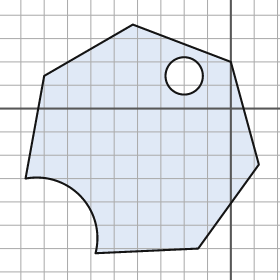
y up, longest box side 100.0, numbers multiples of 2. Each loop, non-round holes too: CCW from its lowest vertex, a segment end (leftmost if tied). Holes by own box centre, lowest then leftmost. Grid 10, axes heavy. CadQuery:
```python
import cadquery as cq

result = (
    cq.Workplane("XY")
    .moveTo(-58.0, -62.0)
    .lineTo(-14.0, -60.0)
    .lineTo(12.0, -24.0)
    .lineTo(0.0, 20.0)
    .lineTo(-42.0, 36.0)
    .lineTo(-80.0, 14.0)
    .lineTo(-88.0, -30.0)
    .threePointArc((-64.0, -38.0), (-58.0, -62.0))
    .close()
    .moveTo(-20.0, 14.0)
    .circle(8.0)
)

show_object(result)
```